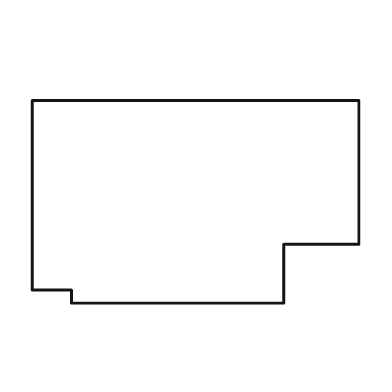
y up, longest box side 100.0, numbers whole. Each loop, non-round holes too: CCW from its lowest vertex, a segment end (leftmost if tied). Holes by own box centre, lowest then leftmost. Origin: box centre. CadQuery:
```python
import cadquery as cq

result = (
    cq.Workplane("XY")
    .moveTo(-38.0, -31.0)
    .lineTo(27.0, -31.0)
    .lineTo(27.0, -13.0)
    .lineTo(50.0, -13.0)
    .lineTo(50.0, 31.0)
    .lineTo(-50.0, 31.0)
    .lineTo(-50.0, -27.0)
    .lineTo(-38.0, -27.0)
    .close()
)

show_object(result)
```